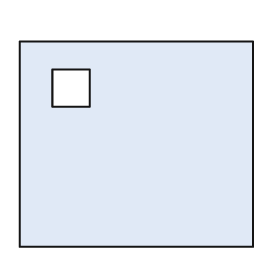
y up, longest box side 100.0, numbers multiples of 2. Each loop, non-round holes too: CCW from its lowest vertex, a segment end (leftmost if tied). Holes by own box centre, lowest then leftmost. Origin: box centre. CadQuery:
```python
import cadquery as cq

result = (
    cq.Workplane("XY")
    .moveTo(-50.0, -44.0)
    .lineTo(50.0, -44.0)
    .lineTo(50.0, 44.0)
    .lineTo(-50.0, 44.0)
    .close()
    .moveTo(-36.0, 16.0)
    .lineTo(-20.0, 16.0)
    .lineTo(-20.0, 32.0)
    .lineTo(-36.0, 32.0)
    .close()
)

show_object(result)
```